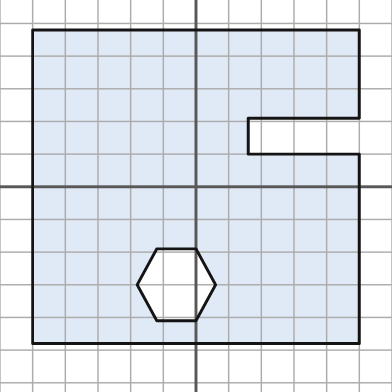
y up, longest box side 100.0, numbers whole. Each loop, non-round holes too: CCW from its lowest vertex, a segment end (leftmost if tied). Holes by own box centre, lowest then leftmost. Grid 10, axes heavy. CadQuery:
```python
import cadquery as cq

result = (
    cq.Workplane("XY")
    .moveTo(-50.0, -48.0)
    .lineTo(50.0, -48.0)
    .lineTo(50.0, 10.0)
    .lineTo(16.0, 10.0)
    .lineTo(16.0, 21.0)
    .lineTo(50.0, 21.0)
    .lineTo(50.0, 48.0)
    .lineTo(-50.0, 48.0)
    .close()
    .moveTo(-12.0, -41.0)
    .lineTo(0.0, -41.0)
    .lineTo(6.0, -30.0)
    .lineTo(0.0, -19.0)
    .lineTo(-12.0, -19.0)
    .lineTo(-18.0, -30.0)
    .close()
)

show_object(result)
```